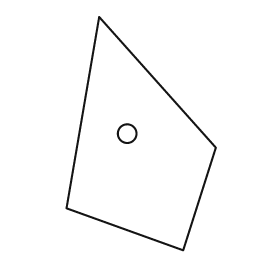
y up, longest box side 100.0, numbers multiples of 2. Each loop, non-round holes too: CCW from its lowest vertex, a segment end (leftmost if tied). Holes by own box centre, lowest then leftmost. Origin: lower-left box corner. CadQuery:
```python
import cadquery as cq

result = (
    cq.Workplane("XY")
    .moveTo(50.0, 0.0)
    .lineTo(64.0, 44.0)
    .lineTo(14.0, 100.0)
    .lineTo(0.0, 18.0)
    .close()
    .moveTo(26.0, 50.0)
    .circle(4.0)
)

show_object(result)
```